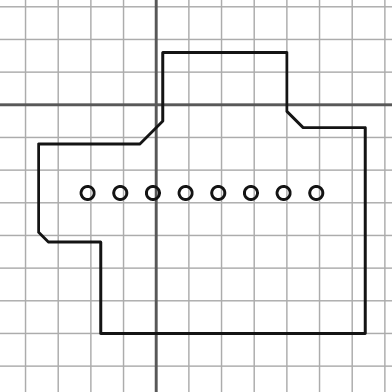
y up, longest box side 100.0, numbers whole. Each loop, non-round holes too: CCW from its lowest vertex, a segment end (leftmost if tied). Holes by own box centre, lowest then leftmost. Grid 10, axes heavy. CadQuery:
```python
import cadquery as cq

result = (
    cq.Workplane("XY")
    .moveTo(-17.0, -70.0)
    .lineTo(64.0, -70.0)
    .lineTo(64.0, -7.0)
    .lineTo(45.0, -7.0)
    .lineTo(40.0, -2.0)
    .lineTo(40.0, 16.0)
    .lineTo(2.0, 16.0)
    .lineTo(2.0, -5.0)
    .lineTo(-5.0, -12.0)
    .lineTo(-36.0, -12.0)
    .lineTo(-36.0, -39.0)
    .lineTo(-33.0, -42.0)
    .lineTo(-17.0, -42.0)
    .close()
    .moveTo(-21.0, -27.0)
    .circle(2.0)
    .moveTo(-11.0, -27.0)
    .circle(2.0)
    .moveTo(-1.0, -27.0)
    .circle(2.0)
    .moveTo(9.0, -27.0)
    .circle(2.0)
    .moveTo(19.0, -27.0)
    .circle(2.0)
    .moveTo(29.0, -27.0)
    .circle(2.0)
    .moveTo(39.0, -27.0)
    .circle(2.0)
    .moveTo(49.0, -27.0)
    .circle(2.0)
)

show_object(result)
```